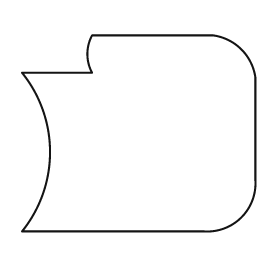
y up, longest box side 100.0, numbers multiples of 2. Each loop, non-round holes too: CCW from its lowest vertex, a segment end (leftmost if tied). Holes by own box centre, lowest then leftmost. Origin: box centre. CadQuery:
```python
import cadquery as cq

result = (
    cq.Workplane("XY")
    .moveTo(-50.0, -42.0)
    .lineTo(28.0, -42.0)
    .threePointArc((44.0, -36.0), (50.0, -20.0))
    .lineTo(50.0, 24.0)
    .threePointArc((44.0, 36.0), (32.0, 42.0))
    .lineTo(-20.0, 42.0)
    .threePointArc((-22.0, 34.0), (-20.0, 26.0))
    .lineTo(-50.0, 26.0)
    .threePointArc((-38.0, -8.0), (-50.0, -42.0))
    .close()
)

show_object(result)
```